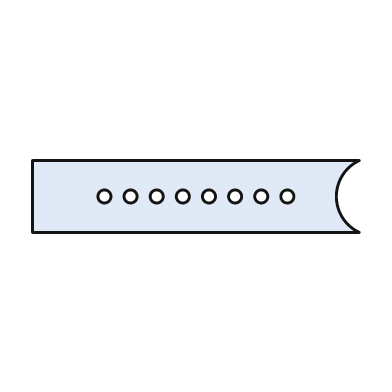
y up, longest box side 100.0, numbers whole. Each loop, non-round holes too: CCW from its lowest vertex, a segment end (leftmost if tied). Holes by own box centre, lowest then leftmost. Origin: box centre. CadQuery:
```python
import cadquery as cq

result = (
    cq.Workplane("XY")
    .moveTo(-50.0, -11.0)
    .lineTo(50.0, -11.0)
    .threePointArc((43.0, 0.0), (50.0, 11.0))
    .lineTo(-50.0, 11.0)
    .close()
    .moveTo(-28.0, 0.0)
    .circle(2.0)
    .moveTo(-20.0, 0.0)
    .circle(2.0)
    .moveTo(-12.0, 0.0)
    .circle(2.0)
    .moveTo(-4.0, 0.0)
    .circle(2.0)
    .moveTo(4.0, 0.0)
    .circle(2.0)
    .moveTo(12.0, 0.0)
    .circle(2.0)
    .moveTo(20.0, 0.0)
    .circle(2.0)
    .moveTo(28.0, 0.0)
    .circle(2.0)
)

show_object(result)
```